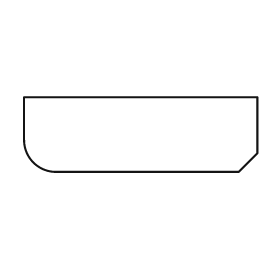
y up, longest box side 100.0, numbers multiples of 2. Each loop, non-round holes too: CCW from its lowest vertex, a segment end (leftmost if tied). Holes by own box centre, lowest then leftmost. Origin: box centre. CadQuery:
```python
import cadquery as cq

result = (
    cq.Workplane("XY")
    .moveTo(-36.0, -16.0)
    .lineTo(42.0, -16.0)
    .lineTo(50.0, -8.0)
    .lineTo(50.0, 16.0)
    .lineTo(-50.0, 16.0)
    .lineTo(-50.0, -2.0)
    .threePointArc((-46.0, -12.0), (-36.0, -16.0))
    .close()
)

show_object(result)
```